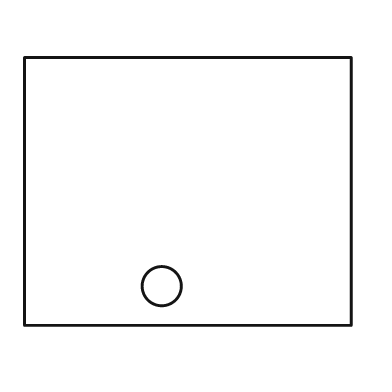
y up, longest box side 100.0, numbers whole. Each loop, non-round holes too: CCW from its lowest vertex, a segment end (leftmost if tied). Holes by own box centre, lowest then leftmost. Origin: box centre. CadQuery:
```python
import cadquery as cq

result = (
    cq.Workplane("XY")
    .moveTo(-50.0, -41.0)
    .lineTo(50.0, -41.0)
    .lineTo(50.0, 41.0)
    .lineTo(-50.0, 41.0)
    .close()
    .moveTo(-8.0, -29.0)
    .circle(6.0)
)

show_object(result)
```